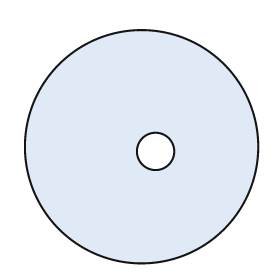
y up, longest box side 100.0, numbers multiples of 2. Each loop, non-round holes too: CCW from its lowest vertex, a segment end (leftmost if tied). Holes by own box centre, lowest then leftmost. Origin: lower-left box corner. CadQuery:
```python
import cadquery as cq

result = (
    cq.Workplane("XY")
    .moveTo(50.0, 50.0)
    .circle(50.0)
    .moveTo(56.0, 48.0)
    .circle(8.0)
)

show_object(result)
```